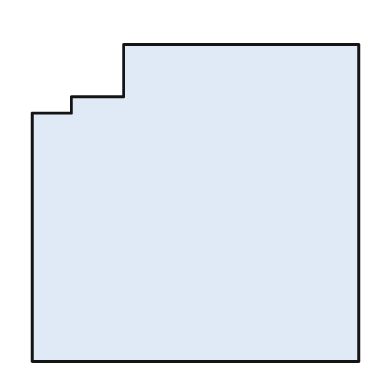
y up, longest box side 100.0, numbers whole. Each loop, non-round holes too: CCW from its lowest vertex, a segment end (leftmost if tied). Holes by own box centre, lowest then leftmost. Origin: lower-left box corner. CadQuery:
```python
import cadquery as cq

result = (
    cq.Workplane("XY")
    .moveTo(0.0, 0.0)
    .lineTo(100.0, 0.0)
    .lineTo(100.0, 97.0)
    .lineTo(28.0, 97.0)
    .lineTo(28.0, 81.0)
    .lineTo(12.0, 81.0)
    .lineTo(12.0, 76.0)
    .lineTo(0.0, 76.0)
    .close()
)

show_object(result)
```